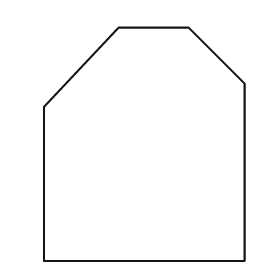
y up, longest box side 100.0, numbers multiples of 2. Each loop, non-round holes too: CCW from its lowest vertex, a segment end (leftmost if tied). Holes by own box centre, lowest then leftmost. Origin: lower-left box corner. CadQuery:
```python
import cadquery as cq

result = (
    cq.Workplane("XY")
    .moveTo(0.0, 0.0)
    .lineTo(86.0, 0.0)
    .lineTo(86.0, 76.0)
    .lineTo(62.0, 100.0)
    .lineTo(32.0, 100.0)
    .lineTo(0.0, 66.0)
    .close()
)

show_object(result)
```